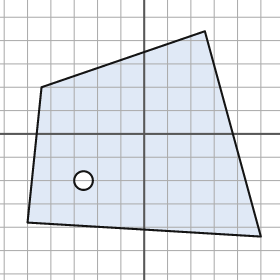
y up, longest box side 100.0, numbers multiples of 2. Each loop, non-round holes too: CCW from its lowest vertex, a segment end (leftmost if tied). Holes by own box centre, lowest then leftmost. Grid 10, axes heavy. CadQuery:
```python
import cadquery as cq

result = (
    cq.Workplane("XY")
    .moveTo(50.0, -44.0)
    .lineTo(26.0, 44.0)
    .lineTo(-44.0, 20.0)
    .lineTo(-50.0, -38.0)
    .close()
    .moveTo(-26.0, -20.0)
    .circle(4.0)
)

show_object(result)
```